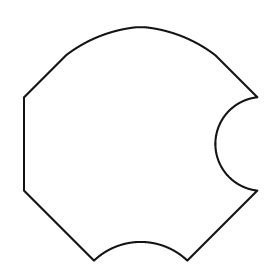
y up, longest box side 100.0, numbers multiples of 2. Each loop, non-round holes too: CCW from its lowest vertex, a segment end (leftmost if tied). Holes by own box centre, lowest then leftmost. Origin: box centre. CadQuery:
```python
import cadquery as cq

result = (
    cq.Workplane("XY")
    .moveTo(-20.0, -50.0)
    .threePointArc((0.0, -42.0), (20.0, -50.0))
    .lineTo(50.0, -20.0)
    .threePointArc((32.0, 0.0), (50.0, 20.0))
    .lineTo(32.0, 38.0)
    .threePointArc((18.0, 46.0), (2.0, 50.0))
    .lineTo(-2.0, 50.0)
    .threePointArc((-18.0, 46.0), (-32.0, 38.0))
    .lineTo(-50.0, 20.0)
    .lineTo(-50.0, -20.0)
    .close()
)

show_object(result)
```